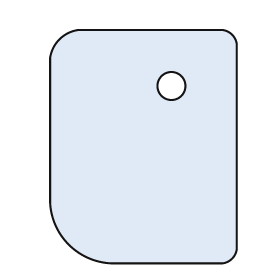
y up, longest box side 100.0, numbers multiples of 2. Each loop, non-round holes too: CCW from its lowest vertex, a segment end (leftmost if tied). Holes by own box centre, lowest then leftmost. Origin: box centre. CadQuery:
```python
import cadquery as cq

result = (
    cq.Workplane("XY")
    .moveTo(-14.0, -50.0)
    .lineTo(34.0, -50.0)
    .threePointArc((38.0, -48.0), (40.0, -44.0))
    .lineTo(40.0, 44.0)
    .threePointArc((38.0, 48.0), (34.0, 50.0))
    .lineTo(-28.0, 50.0)
    .threePointArc((-36.0, 46.0), (-40.0, 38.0))
    .lineTo(-40.0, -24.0)
    .threePointArc((-32.0, -42.0), (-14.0, -50.0))
    .close()
    .moveTo(12.0, 26.0)
    .circle(6.0)
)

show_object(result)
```